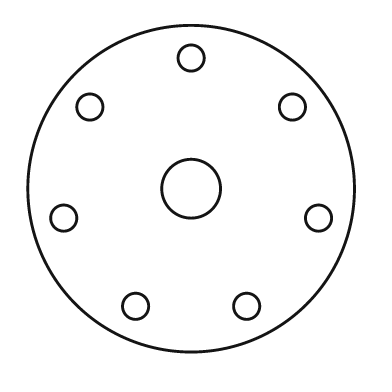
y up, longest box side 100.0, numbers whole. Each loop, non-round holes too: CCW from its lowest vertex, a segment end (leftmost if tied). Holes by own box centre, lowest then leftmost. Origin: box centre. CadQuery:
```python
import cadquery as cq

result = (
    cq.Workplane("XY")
    .moveTo(0.0, 0.0)
    .circle(50.0)
    .moveTo(-17.0, -36.0)
    .circle(4.0)
    .moveTo(17.0, -36.0)
    .circle(4.0)
    .moveTo(-39.0, -9.0)
    .circle(4.0)
    .moveTo(39.0, -9.0)
    .circle(4.0)
    .moveTo(0.0, 0.0)
    .circle(9.0)
    .moveTo(-31.0, 25.0)
    .circle(4.0)
    .moveTo(31.0, 25.0)
    .circle(4.0)
    .moveTo(0.0, 40.0)
    .circle(4.0)
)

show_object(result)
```